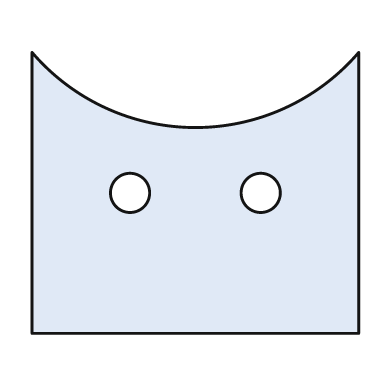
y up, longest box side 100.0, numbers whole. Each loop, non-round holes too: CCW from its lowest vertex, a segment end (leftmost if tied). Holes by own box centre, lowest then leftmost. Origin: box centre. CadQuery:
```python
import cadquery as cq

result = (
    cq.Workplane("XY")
    .moveTo(-50.0, -43.0)
    .lineTo(50.0, -43.0)
    .lineTo(50.0, 43.0)
    .threePointArc((0.0, 20.0), (-50.0, 43.0))
    .close()
    .moveTo(-20.0, 0.0)
    .circle(6.0)
    .moveTo(20.0, 0.0)
    .circle(6.0)
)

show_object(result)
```